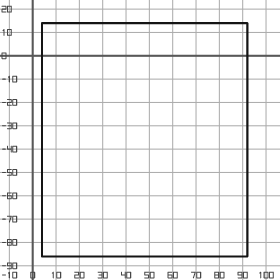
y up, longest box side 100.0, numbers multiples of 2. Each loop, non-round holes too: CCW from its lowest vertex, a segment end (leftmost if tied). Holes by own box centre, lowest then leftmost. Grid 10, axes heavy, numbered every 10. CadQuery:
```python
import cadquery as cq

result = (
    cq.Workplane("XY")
    .moveTo(4.0, -86.0)
    .lineTo(92.0, -86.0)
    .lineTo(92.0, 14.0)
    .lineTo(4.0, 14.0)
    .close()
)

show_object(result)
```